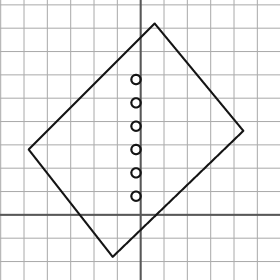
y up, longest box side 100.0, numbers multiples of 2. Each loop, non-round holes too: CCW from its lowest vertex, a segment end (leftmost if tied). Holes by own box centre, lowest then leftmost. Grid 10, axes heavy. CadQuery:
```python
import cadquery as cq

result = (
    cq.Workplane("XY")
    .moveTo(-12.0, -18.0)
    .lineTo(44.0, 36.0)
    .lineTo(6.0, 82.0)
    .lineTo(-48.0, 28.0)
    .close()
    .moveTo(-2.0, 8.0)
    .circle(2.0)
    .moveTo(-2.0, 18.0)
    .circle(2.0)
    .moveTo(-2.0, 28.0)
    .circle(2.0)
    .moveTo(-2.0, 38.0)
    .circle(2.0)
    .moveTo(-2.0, 48.0)
    .circle(2.0)
    .moveTo(-2.0, 58.0)
    .circle(2.0)
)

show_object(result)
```